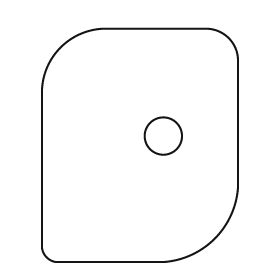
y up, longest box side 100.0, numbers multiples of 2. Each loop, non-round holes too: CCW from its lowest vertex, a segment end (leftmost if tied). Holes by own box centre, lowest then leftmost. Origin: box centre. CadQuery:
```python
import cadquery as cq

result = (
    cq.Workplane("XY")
    .moveTo(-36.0, -50.0)
    .lineTo(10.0, -50.0)
    .threePointArc((32.0, -40.0), (42.0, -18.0))
    .lineTo(42.0, 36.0)
    .threePointArc((38.0, 46.0), (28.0, 50.0))
    .lineTo(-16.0, 50.0)
    .threePointArc((-34.0, 42.0), (-42.0, 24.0))
    .lineTo(-42.0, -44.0)
    .threePointArc((-40.0, -48.0), (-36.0, -50.0))
    .close()
    .moveTo(10.0, 4.0)
    .circle(8.0)
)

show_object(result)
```